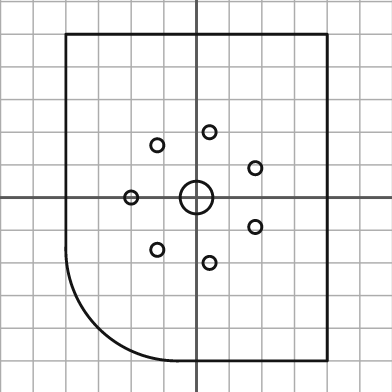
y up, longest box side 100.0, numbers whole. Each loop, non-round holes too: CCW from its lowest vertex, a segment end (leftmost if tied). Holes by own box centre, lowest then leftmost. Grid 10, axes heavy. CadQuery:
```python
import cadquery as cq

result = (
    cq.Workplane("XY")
    .moveTo(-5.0, -50.0)
    .lineTo(40.0, -50.0)
    .lineTo(40.0, 50.0)
    .lineTo(-40.0, 50.0)
    .lineTo(-40.0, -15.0)
    .threePointArc((-30.0, -40.0), (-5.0, -50.0))
    .close()
    .moveTo(4.0, -20.0)
    .circle(2.0)
    .moveTo(-12.0, -16.0)
    .circle(2.0)
    .moveTo(18.0, -9.0)
    .circle(2.0)
    .moveTo(-20.0, 0.0)
    .circle(2.0)
    .moveTo(0.0, 0.0)
    .circle(5.0)
    .moveTo(18.0, 9.0)
    .circle(2.0)
    .moveTo(-12.0, 16.0)
    .circle(2.0)
    .moveTo(4.0, 20.0)
    .circle(2.0)
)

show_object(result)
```